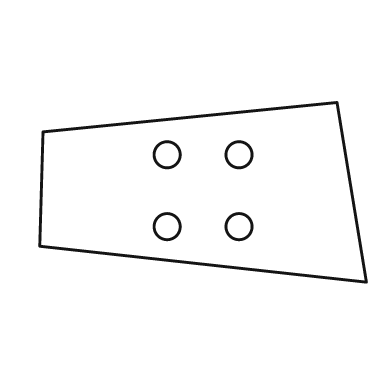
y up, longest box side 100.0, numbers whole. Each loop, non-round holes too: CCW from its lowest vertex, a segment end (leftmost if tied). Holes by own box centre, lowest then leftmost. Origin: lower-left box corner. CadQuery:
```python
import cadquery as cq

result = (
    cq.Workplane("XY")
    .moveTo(100.0, 0.0)
    .lineTo(91.0, 55.0)
    .lineTo(1.0, 46.0)
    .lineTo(0.0, 11.0)
    .close()
    .moveTo(39.0, 17.0)
    .circle(4.0)
    .moveTo(61.0, 17.0)
    .circle(4.0)
    .moveTo(39.0, 39.0)
    .circle(4.0)
    .moveTo(61.0, 39.0)
    .circle(4.0)
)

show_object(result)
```